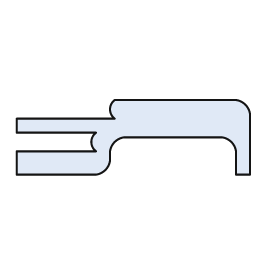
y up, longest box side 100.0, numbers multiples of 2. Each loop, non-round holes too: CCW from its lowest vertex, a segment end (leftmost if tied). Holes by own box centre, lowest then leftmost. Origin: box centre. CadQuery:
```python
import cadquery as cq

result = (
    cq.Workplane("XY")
    .moveTo(-50.0, -16.0)
    .lineTo(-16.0, -16.0)
    .threePointArc((-12.0, -14.0), (-10.0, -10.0))
    .lineTo(-10.0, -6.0)
    .threePointArc((-8.0, -2.0), (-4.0, 0.0))
    .lineTo(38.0, 0.0)
    .threePointArc((42.0, -2.0), (44.0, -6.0))
    .lineTo(44.0, -16.0)
    .lineTo(50.0, -16.0)
    .lineTo(50.0, 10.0)
    .threePointArc((48.0, 14.0), (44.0, 16.0))
    .lineTo(-8.0, 16.0)
    .threePointArc((-10.0, 12.0), (-8.0, 8.0))
    .lineTo(-50.0, 8.0)
    .lineTo(-50.0, 2.0)
    .lineTo(-16.0, 2.0)
    .threePointArc((-18.0, -2.0), (-16.0, -6.0))
    .lineTo(-50.0, -6.0)
    .close()
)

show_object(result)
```